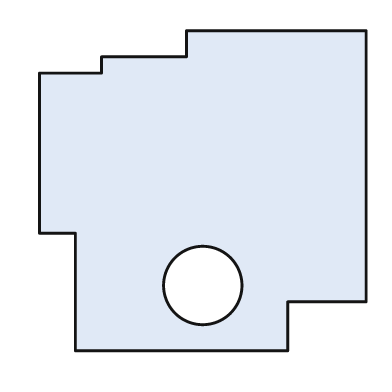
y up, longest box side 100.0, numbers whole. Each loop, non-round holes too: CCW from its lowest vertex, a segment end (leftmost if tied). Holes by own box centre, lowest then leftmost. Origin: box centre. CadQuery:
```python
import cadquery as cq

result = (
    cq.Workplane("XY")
    .moveTo(-39.0, -49.0)
    .lineTo(26.0, -49.0)
    .lineTo(26.0, -34.0)
    .lineTo(50.0, -34.0)
    .lineTo(50.0, 49.0)
    .lineTo(-5.0, 49.0)
    .lineTo(-5.0, 41.0)
    .lineTo(-31.0, 41.0)
    .lineTo(-31.0, 36.0)
    .lineTo(-50.0, 36.0)
    .lineTo(-50.0, -13.0)
    .lineTo(-39.0, -13.0)
    .close()
    .moveTo(0.0, -29.0)
    .circle(12.0)
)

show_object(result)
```